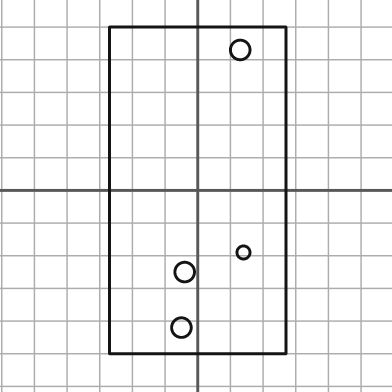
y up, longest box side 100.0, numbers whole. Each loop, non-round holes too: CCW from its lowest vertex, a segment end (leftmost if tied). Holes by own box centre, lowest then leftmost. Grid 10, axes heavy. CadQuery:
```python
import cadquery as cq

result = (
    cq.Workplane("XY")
    .moveTo(-27.0, -50.0)
    .lineTo(27.0, -50.0)
    .lineTo(27.0, 50.0)
    .lineTo(-27.0, 50.0)
    .close()
    .moveTo(-5.0, -42.0)
    .circle(3.0)
    .moveTo(-4.0, -25.0)
    .circle(3.0)
    .moveTo(14.0, -19.0)
    .circle(2.0)
    .moveTo(13.0, 43.0)
    .circle(3.0)
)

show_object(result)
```